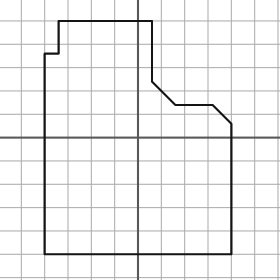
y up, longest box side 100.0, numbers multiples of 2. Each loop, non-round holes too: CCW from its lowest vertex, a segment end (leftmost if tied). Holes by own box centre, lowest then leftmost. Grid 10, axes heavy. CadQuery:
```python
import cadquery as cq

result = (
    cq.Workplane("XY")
    .moveTo(-40.0, -50.0)
    .lineTo(40.0, -50.0)
    .lineTo(40.0, 6.0)
    .lineTo(32.0, 14.0)
    .lineTo(16.0, 14.0)
    .lineTo(6.0, 24.0)
    .lineTo(6.0, 50.0)
    .lineTo(-34.0, 50.0)
    .lineTo(-34.0, 36.0)
    .lineTo(-40.0, 36.0)
    .close()
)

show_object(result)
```